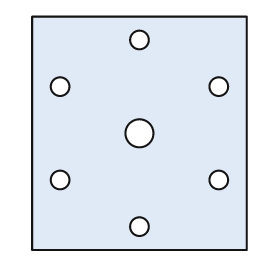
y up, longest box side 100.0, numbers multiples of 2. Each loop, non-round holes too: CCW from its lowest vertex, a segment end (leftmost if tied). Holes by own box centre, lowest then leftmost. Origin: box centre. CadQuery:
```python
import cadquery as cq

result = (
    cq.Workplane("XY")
    .moveTo(-46.0, -50.0)
    .lineTo(46.0, -50.0)
    .lineTo(46.0, 50.0)
    .lineTo(-46.0, 50.0)
    .close()
    .moveTo(0.0, -40.0)
    .circle(4.0)
    .moveTo(-34.0, -20.0)
    .circle(4.0)
    .moveTo(34.0, -20.0)
    .circle(4.0)
    .moveTo(0.0, 0.0)
    .circle(6.0)
    .moveTo(-34.0, 20.0)
    .circle(4.0)
    .moveTo(34.0, 20.0)
    .circle(4.0)
    .moveTo(0.0, 40.0)
    .circle(4.0)
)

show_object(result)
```